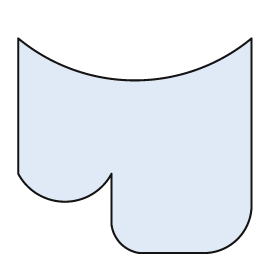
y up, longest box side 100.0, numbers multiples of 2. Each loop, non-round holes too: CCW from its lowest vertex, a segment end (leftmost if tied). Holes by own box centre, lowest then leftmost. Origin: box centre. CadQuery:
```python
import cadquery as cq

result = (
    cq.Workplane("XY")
    .moveTo(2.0, -46.0)
    .lineTo(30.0, -46.0)
    .threePointArc((44.0, -40.0), (50.0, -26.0))
    .lineTo(50.0, 46.0)
    .threePointArc((0.0, 28.0), (-50.0, 46.0))
    .lineTo(-50.0, -12.0)
    .threePointArc((-30.0, -24.0), (-10.0, -12.0))
    .lineTo(-10.0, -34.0)
    .threePointArc((-6.0, -42.0), (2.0, -46.0))
    .close()
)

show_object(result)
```